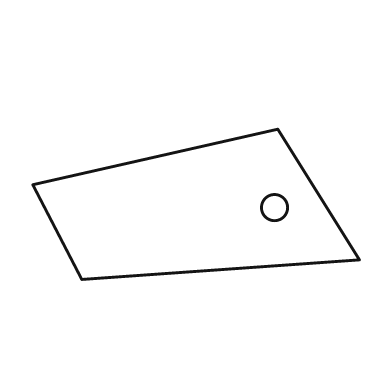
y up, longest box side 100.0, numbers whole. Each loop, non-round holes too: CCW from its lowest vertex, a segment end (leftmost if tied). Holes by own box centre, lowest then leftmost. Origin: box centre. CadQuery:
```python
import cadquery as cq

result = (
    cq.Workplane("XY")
    .moveTo(-35.0, -23.0)
    .lineTo(50.0, -17.0)
    .lineTo(25.0, 23.0)
    .lineTo(-50.0, 6.0)
    .close()
    .moveTo(24.0, -1.0)
    .circle(4.0)
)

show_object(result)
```